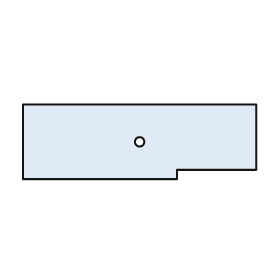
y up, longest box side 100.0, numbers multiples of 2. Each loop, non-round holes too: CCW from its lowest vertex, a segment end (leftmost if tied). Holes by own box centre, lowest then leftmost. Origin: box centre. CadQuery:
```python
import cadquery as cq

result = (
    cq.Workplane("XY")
    .moveTo(-50.0, -16.0)
    .lineTo(16.0, -16.0)
    .lineTo(16.0, -12.0)
    .lineTo(50.0, -12.0)
    .lineTo(50.0, 16.0)
    .lineTo(-50.0, 16.0)
    .close()
    .moveTo(0.0, 0.0)
    .circle(2.0)
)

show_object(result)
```